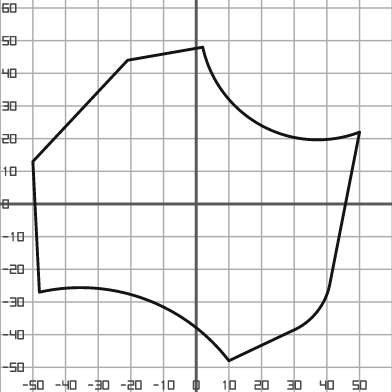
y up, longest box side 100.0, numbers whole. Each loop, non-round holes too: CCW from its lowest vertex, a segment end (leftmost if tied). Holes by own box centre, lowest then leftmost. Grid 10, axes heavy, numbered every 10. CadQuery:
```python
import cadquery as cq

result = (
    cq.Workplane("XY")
    .moveTo(10.0, -48.0)
    .lineTo(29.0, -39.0)
    .threePointArc((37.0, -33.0), (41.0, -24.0))
    .lineTo(50.0, 22.0)
    .threePointArc((20.0, 24.0), (2.0, 48.0))
    .lineTo(-21.0, 44.0)
    .lineTo(-50.0, 13.0)
    .lineTo(-48.0, -27.0)
    .threePointArc((-16.0, -29.0), (10.0, -48.0))
    .close()
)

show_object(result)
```